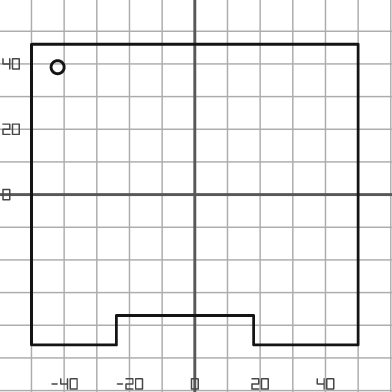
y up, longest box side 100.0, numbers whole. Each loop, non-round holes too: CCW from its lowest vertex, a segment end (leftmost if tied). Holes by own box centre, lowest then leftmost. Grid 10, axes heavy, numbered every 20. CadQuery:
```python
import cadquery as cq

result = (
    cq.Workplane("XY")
    .moveTo(-50.0, -46.0)
    .lineTo(-24.0, -46.0)
    .lineTo(-24.0, -37.0)
    .lineTo(18.0, -37.0)
    .lineTo(18.0, -46.0)
    .lineTo(50.0, -46.0)
    .lineTo(50.0, 46.0)
    .lineTo(-50.0, 46.0)
    .close()
    .moveTo(-42.0, 39.0)
    .circle(2.0)
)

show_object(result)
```